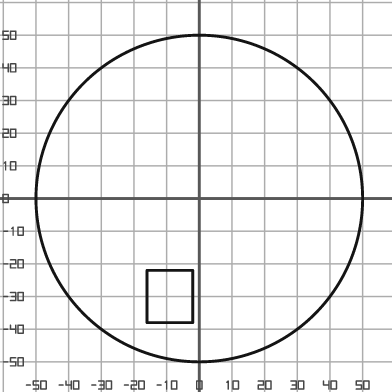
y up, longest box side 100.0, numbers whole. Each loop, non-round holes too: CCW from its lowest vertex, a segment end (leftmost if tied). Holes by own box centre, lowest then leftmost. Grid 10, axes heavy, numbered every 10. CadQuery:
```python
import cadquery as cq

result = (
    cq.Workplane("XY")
    .moveTo(0.0, 0.0)
    .circle(50.0)
    .moveTo(-16.0, -38.0)
    .lineTo(-2.0, -38.0)
    .lineTo(-2.0, -22.0)
    .lineTo(-16.0, -22.0)
    .close()
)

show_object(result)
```